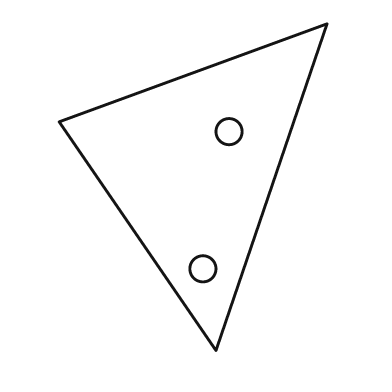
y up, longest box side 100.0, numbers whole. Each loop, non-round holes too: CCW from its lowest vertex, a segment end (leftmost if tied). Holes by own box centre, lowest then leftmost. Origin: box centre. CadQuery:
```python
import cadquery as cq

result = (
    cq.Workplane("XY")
    .moveTo(7.0, -50.0)
    .lineTo(41.0, 50.0)
    .lineTo(-41.0, 20.0)
    .close()
    .moveTo(3.0, -25.0)
    .circle(4.0)
    .moveTo(11.0, 17.0)
    .circle(4.0)
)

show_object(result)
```